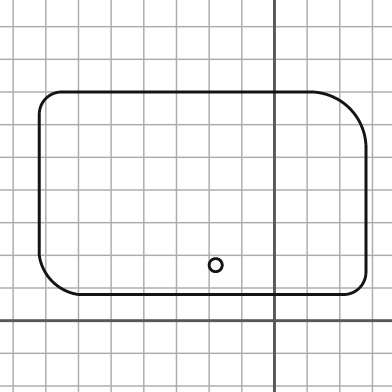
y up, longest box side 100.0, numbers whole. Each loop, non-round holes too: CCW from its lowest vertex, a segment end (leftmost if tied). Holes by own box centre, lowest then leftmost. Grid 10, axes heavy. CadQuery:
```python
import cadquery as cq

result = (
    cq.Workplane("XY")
    .moveTo(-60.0, 8.0)
    .lineTo(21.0, 8.0)
    .threePointArc((26.0, 10.0), (28.0, 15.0))
    .lineTo(28.0, 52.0)
    .threePointArc((23.0, 65.0), (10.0, 70.0))
    .lineTo(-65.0, 70.0)
    .threePointArc((-70.0, 68.0), (-72.0, 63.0))
    .lineTo(-72.0, 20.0)
    .threePointArc((-68.0, 12.0), (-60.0, 8.0))
    .close()
    .moveTo(-18.0, 17.0)
    .circle(2.0)
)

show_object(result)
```